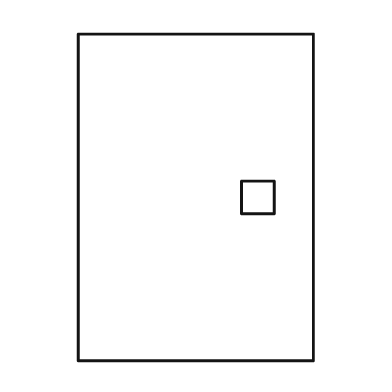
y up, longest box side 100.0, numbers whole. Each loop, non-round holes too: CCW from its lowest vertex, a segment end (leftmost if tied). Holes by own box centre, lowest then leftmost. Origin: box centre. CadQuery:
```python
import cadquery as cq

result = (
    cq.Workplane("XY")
    .moveTo(-36.0, -50.0)
    .lineTo(36.0, -50.0)
    .lineTo(36.0, 50.0)
    .lineTo(-36.0, 50.0)
    .close()
    .moveTo(14.0, -5.0)
    .lineTo(24.0, -5.0)
    .lineTo(24.0, 5.0)
    .lineTo(14.0, 5.0)
    .close()
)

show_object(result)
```